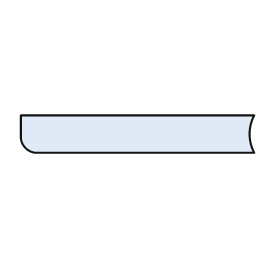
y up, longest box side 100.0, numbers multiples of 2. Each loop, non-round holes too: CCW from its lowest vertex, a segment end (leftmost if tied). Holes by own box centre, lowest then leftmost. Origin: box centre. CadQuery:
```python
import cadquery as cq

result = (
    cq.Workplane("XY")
    .moveTo(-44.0, -8.0)
    .lineTo(50.0, -8.0)
    .threePointArc((48.0, 0.0), (50.0, 8.0))
    .lineTo(-50.0, 8.0)
    .lineTo(-50.0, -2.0)
    .threePointArc((-48.0, -6.0), (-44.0, -8.0))
    .close()
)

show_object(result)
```